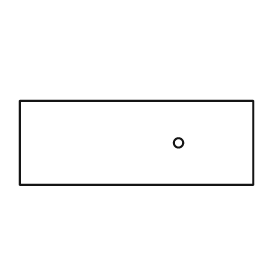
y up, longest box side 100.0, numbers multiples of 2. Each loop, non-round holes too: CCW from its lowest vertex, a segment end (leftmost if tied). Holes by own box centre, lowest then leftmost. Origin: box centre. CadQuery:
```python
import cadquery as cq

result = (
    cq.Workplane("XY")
    .moveTo(-50.0, -18.0)
    .lineTo(50.0, -18.0)
    .lineTo(50.0, 18.0)
    .lineTo(-50.0, 18.0)
    .close()
    .moveTo(18.0, 0.0)
    .circle(2.0)
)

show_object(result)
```